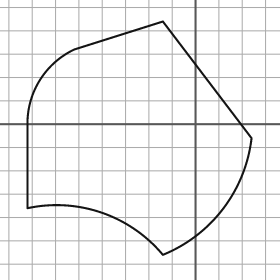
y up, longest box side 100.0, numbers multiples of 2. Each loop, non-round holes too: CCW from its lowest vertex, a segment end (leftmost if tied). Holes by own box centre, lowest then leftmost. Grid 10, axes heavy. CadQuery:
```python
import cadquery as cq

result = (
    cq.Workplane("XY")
    .moveTo(-14.0, -56.0)
    .threePointArc((12.0, -36.0), (24.0, -6.0))
    .lineTo(-14.0, 44.0)
    .lineTo(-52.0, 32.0)
    .threePointArc((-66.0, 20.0), (-72.0, 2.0))
    .lineTo(-72.0, -36.0)
    .threePointArc((-40.0, -38.0), (-14.0, -56.0))
    .close()
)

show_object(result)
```